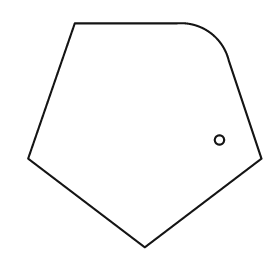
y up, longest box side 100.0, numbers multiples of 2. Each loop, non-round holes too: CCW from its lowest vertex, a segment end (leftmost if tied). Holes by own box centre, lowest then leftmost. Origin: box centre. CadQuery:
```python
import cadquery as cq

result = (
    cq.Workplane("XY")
    .moveTo(0.0, -48.0)
    .lineTo(50.0, -10.0)
    .lineTo(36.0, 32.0)
    .threePointArc((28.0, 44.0), (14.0, 48.0))
    .lineTo(-30.0, 48.0)
    .lineTo(-50.0, -10.0)
    .close()
    .moveTo(32.0, -2.0)
    .circle(2.0)
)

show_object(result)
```